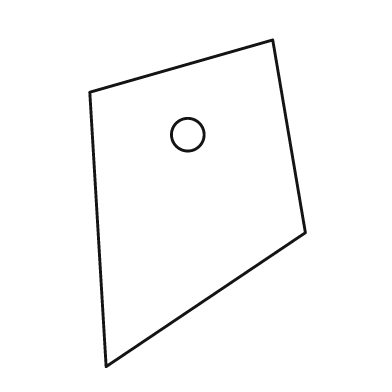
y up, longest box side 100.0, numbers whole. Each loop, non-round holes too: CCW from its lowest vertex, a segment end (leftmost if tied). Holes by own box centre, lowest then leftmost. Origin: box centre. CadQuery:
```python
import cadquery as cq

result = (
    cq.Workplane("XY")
    .moveTo(-28.0, -50.0)
    .lineTo(33.0, -9.0)
    .lineTo(23.0, 50.0)
    .lineTo(-33.0, 34.0)
    .close()
    .moveTo(-3.0, 21.0)
    .circle(5.0)
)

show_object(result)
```